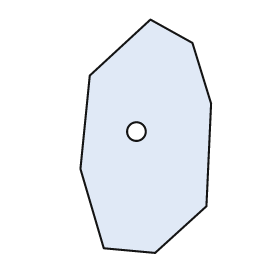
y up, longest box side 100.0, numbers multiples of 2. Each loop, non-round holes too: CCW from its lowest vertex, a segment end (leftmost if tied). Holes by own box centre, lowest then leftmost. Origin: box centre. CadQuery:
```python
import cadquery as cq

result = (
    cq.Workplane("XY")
    .moveTo(4.0, -50.0)
    .lineTo(26.0, -30.0)
    .lineTo(28.0, 14.0)
    .lineTo(20.0, 40.0)
    .lineTo(2.0, 50.0)
    .lineTo(-24.0, 26.0)
    .lineTo(-28.0, -14.0)
    .lineTo(-18.0, -48.0)
    .close()
    .moveTo(-4.0, 2.0)
    .circle(4.0)
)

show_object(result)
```